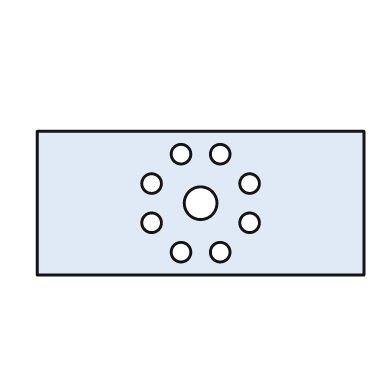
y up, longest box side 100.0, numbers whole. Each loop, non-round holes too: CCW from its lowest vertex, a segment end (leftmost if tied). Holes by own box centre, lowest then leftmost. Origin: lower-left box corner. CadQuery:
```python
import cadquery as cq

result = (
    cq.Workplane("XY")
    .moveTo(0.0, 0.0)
    .lineTo(100.0, 0.0)
    .lineTo(100.0, 44.0)
    .lineTo(0.0, 44.0)
    .close()
    .moveTo(44.0, 7.0)
    .circle(3.0)
    .moveTo(56.0, 7.0)
    .circle(3.0)
    .moveTo(35.0, 16.0)
    .circle(3.0)
    .moveTo(65.0, 16.0)
    .circle(3.0)
    .moveTo(50.0, 22.0)
    .circle(5.0)
    .moveTo(35.0, 28.0)
    .circle(3.0)
    .moveTo(65.0, 28.0)
    .circle(3.0)
    .moveTo(44.0, 37.0)
    .circle(3.0)
    .moveTo(56.0, 37.0)
    .circle(3.0)
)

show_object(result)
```